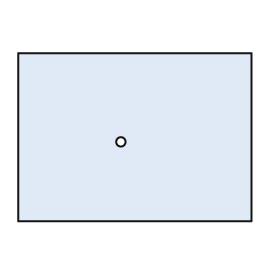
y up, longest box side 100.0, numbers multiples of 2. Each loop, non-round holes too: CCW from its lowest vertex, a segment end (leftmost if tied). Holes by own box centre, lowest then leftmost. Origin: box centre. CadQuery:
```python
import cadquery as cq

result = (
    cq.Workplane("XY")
    .moveTo(-50.0, -36.0)
    .lineTo(50.0, -36.0)
    .lineTo(50.0, 36.0)
    .lineTo(-50.0, 36.0)
    .close()
    .moveTo(-6.0, -2.0)
    .circle(2.0)
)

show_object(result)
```